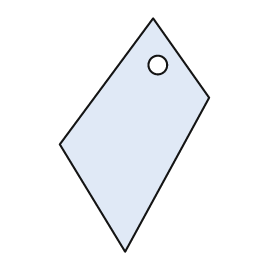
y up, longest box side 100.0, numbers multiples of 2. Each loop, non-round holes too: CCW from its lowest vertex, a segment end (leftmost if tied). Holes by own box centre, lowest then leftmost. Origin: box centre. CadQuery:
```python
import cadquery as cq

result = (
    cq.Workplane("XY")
    .moveTo(-4.0, -50.0)
    .lineTo(32.0, 16.0)
    .lineTo(8.0, 50.0)
    .lineTo(-32.0, -4.0)
    .close()
    .moveTo(10.0, 30.0)
    .circle(4.0)
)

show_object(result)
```